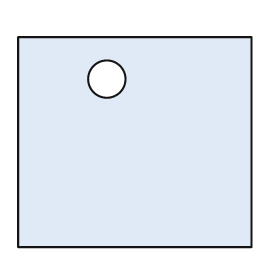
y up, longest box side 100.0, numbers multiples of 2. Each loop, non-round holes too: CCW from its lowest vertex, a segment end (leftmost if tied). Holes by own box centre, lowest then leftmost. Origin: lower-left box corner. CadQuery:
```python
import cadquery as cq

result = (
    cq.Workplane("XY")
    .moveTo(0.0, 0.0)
    .lineTo(100.0, 0.0)
    .lineTo(100.0, 90.0)
    .lineTo(0.0, 90.0)
    .close()
    .moveTo(38.0, 72.0)
    .circle(8.0)
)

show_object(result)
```